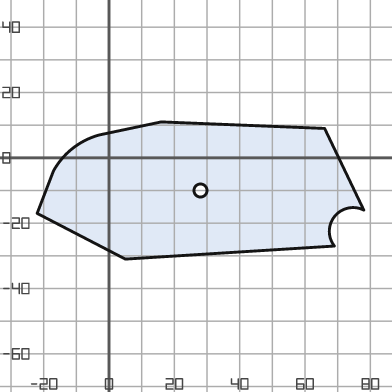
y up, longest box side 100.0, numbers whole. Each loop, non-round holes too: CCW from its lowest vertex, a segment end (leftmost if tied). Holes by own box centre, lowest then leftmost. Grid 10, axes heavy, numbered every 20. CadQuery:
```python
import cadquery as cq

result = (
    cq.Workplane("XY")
    .moveTo(5.0, -31.0)
    .lineTo(69.0, -27.0)
    .threePointArc((69.0, -18.0), (78.0, -16.0))
    .lineTo(66.0, 9.0)
    .lineTo(16.0, 11.0)
    .lineTo(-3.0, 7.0)
    .threePointArc((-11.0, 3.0), (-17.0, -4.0))
    .lineTo(-22.0, -17.0)
    .close()
    .moveTo(28.0, -10.0)
    .circle(2.0)
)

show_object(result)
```